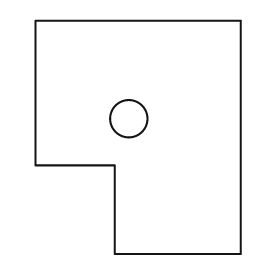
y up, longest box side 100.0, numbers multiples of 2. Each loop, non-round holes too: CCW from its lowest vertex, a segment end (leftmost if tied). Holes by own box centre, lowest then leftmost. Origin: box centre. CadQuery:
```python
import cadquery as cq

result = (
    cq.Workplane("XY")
    .moveTo(-10.0, -50.0)
    .lineTo(44.0, -50.0)
    .lineTo(44.0, 50.0)
    .lineTo(-44.0, 50.0)
    .lineTo(-44.0, -12.0)
    .lineTo(-10.0, -12.0)
    .close()
    .moveTo(-4.0, 8.0)
    .circle(8.0)
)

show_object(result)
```